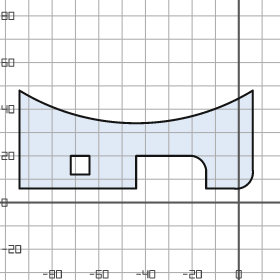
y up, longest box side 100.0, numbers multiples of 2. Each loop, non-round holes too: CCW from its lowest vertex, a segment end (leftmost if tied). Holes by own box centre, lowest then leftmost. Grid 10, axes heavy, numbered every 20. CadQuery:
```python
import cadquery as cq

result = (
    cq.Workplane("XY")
    .moveTo(-94.0, 6.0)
    .lineTo(-44.0, 6.0)
    .lineTo(-44.0, 20.0)
    .lineTo(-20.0, 20.0)
    .threePointArc((-16.0, 18.0), (-14.0, 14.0))
    .lineTo(-14.0, 6.0)
    .lineTo(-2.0, 6.0)
    .threePointArc((4.0, 8.0), (6.0, 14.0))
    .lineTo(6.0, 48.0)
    .threePointArc((-44.0, 34.0), (-94.0, 48.0))
    .close()
    .moveTo(-72.0, 12.0)
    .lineTo(-64.0, 12.0)
    .lineTo(-64.0, 20.0)
    .lineTo(-72.0, 20.0)
    .close()
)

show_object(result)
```